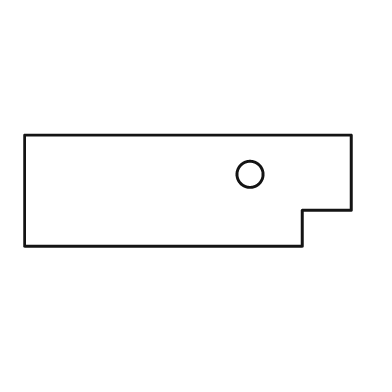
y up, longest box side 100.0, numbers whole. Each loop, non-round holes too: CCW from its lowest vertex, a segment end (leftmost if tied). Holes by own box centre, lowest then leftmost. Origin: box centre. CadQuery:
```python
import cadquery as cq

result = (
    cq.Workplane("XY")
    .moveTo(-50.0, -17.0)
    .lineTo(35.0, -17.0)
    .lineTo(35.0, -6.0)
    .lineTo(50.0, -6.0)
    .lineTo(50.0, 17.0)
    .lineTo(-50.0, 17.0)
    .close()
    .moveTo(19.0, 5.0)
    .circle(4.0)
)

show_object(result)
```